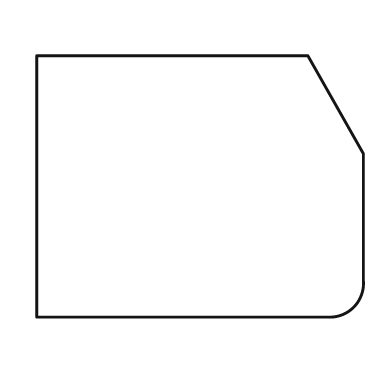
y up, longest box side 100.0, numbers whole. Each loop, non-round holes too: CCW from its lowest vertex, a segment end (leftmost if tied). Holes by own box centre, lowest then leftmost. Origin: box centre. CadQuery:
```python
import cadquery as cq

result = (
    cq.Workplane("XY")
    .moveTo(-50.0, -40.0)
    .lineTo(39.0, -40.0)
    .threePointArc((47.0, -37.0), (50.0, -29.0))
    .lineTo(50.0, 10.0)
    .lineTo(33.0, 40.0)
    .lineTo(-50.0, 40.0)
    .close()
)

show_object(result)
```